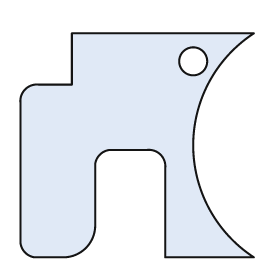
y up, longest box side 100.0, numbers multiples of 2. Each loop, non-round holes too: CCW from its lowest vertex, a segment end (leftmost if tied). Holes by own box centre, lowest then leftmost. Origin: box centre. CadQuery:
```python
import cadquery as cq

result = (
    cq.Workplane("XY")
    .moveTo(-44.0, -48.0)
    .lineTo(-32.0, -48.0)
    .threePointArc((-22.0, -44.0), (-18.0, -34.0))
    .lineTo(-18.0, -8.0)
    .threePointArc((-16.0, -4.0), (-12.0, -2.0))
    .lineTo(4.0, -2.0)
    .threePointArc((10.0, -4.0), (12.0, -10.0))
    .lineTo(12.0, -48.0)
    .lineTo(50.0, -48.0)
    .threePointArc((24.0, 0.0), (50.0, 48.0))
    .lineTo(-28.0, 48.0)
    .lineTo(-28.0, 26.0)
    .lineTo(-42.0, 26.0)
    .threePointArc((-48.0, 24.0), (-50.0, 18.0))
    .lineTo(-50.0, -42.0)
    .threePointArc((-48.0, -46.0), (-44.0, -48.0))
    .close()
    .moveTo(24.0, 36.0)
    .circle(6.0)
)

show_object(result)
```